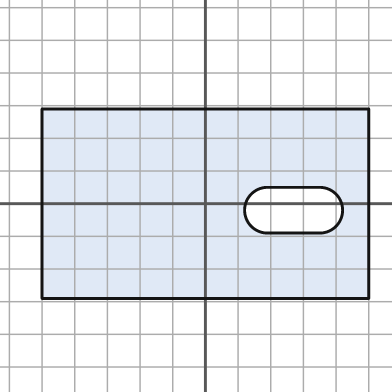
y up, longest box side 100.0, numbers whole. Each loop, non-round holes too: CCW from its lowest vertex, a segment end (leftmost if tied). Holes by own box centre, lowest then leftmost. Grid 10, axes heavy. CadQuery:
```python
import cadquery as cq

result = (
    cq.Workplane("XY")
    .moveTo(-50.0, -29.0)
    .lineTo(50.0, -29.0)
    .lineTo(50.0, 29.0)
    .lineTo(-50.0, 29.0)
    .close()
    .moveTo(19.0, -9.0)
    .lineTo(35.0, -9.0)
    .threePointArc((42.0, -2.0), (35.0, 5.0))
    .lineTo(19.0, 5.0)
    .threePointArc((12.0, -2.0), (19.0, -9.0))
    .close()
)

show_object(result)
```